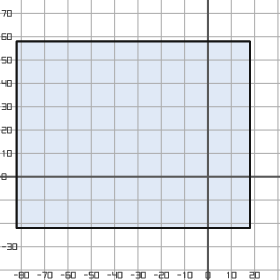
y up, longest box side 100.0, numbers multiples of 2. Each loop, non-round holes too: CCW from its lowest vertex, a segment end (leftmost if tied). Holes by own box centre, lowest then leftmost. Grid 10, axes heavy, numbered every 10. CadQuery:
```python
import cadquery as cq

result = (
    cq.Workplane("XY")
    .moveTo(-82.0, -22.0)
    .lineTo(18.0, -22.0)
    .lineTo(18.0, 58.0)
    .lineTo(-82.0, 58.0)
    .close()
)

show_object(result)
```